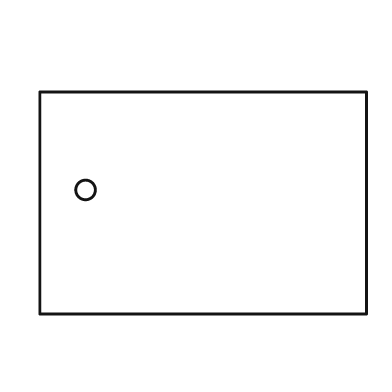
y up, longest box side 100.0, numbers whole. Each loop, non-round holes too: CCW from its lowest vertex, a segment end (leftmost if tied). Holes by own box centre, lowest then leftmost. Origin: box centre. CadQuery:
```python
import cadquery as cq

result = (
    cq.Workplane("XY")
    .moveTo(-50.0, -34.0)
    .lineTo(50.0, -34.0)
    .lineTo(50.0, 34.0)
    .lineTo(-50.0, 34.0)
    .close()
    .moveTo(-36.0, 4.0)
    .circle(3.0)
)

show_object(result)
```